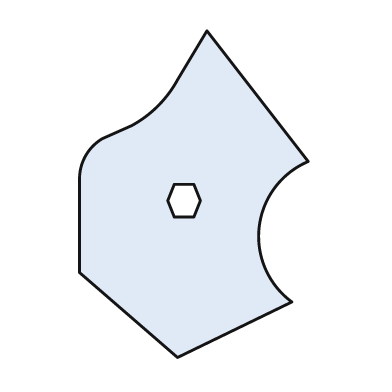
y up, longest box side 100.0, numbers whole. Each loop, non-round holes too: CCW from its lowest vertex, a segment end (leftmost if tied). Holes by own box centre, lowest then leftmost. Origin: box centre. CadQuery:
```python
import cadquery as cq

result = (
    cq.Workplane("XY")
    .moveTo(-5.0, -50.0)
    .lineTo(30.0, -33.0)
    .threePointArc((20.0, -10.0), (35.0, 10.0))
    .lineTo(4.0, 50.0)
    .lineTo(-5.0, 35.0)
    .threePointArc((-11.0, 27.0), (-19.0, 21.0))
    .lineTo(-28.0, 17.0)
    .threePointArc((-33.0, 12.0), (-35.0, 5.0))
    .lineTo(-35.0, -24.0)
    .close()
    .moveTo(-6.0, -7.0)
    .lineTo(0.0, -7.0)
    .lineTo(2.0, -2.0)
    .lineTo(0.0, 3.0)
    .lineTo(-6.0, 3.0)
    .lineTo(-8.0, -2.0)
    .close()
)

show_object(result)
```